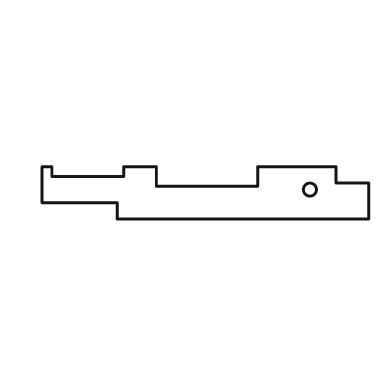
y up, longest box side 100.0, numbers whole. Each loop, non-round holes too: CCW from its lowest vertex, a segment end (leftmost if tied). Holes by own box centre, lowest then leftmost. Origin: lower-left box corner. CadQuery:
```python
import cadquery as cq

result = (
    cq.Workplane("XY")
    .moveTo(23.0, 0.0)
    .lineTo(100.0, 0.0)
    .lineTo(100.0, 11.0)
    .lineTo(90.0, 11.0)
    .lineTo(90.0, 16.0)
    .lineTo(66.0, 16.0)
    .lineTo(66.0, 10.0)
    .lineTo(35.0, 10.0)
    .lineTo(35.0, 16.0)
    .lineTo(25.0, 16.0)
    .lineTo(25.0, 13.0)
    .lineTo(3.0, 13.0)
    .lineTo(3.0, 16.0)
    .lineTo(0.0, 16.0)
    .lineTo(0.0, 5.0)
    .lineTo(23.0, 5.0)
    .close()
    .moveTo(82.0, 9.0)
    .circle(2.0)
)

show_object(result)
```